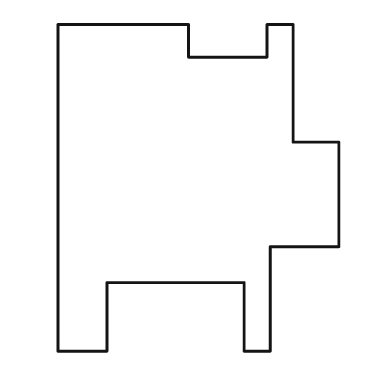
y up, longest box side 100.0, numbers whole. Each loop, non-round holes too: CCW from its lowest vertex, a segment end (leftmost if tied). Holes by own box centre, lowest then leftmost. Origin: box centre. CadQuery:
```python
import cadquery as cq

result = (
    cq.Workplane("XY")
    .moveTo(-43.0, -50.0)
    .lineTo(-28.0, -50.0)
    .lineTo(-28.0, -29.0)
    .lineTo(14.0, -29.0)
    .lineTo(14.0, -50.0)
    .lineTo(22.0, -50.0)
    .lineTo(22.0, -18.0)
    .lineTo(43.0, -18.0)
    .lineTo(43.0, 14.0)
    .lineTo(29.0, 14.0)
    .lineTo(29.0, 50.0)
    .lineTo(21.0, 50.0)
    .lineTo(21.0, 40.0)
    .lineTo(-3.0, 40.0)
    .lineTo(-3.0, 50.0)
    .lineTo(-43.0, 50.0)
    .close()
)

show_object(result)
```